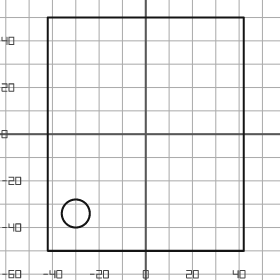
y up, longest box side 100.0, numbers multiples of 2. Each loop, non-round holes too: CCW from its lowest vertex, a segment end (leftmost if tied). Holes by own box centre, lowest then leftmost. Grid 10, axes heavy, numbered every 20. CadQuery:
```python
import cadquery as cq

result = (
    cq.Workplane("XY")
    .moveTo(-42.0, -50.0)
    .lineTo(42.0, -50.0)
    .lineTo(42.0, 50.0)
    .lineTo(-42.0, 50.0)
    .close()
    .moveTo(-30.0, -34.0)
    .circle(6.0)
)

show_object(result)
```